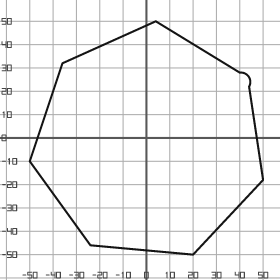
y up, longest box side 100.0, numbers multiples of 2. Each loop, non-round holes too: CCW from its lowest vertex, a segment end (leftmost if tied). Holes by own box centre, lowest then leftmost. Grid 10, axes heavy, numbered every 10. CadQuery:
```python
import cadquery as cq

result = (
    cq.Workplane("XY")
    .moveTo(20.0, -50.0)
    .lineTo(50.0, -18.0)
    .lineTo(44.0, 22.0)
    .threePointArc((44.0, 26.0), (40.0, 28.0))
    .lineTo(4.0, 50.0)
    .lineTo(-36.0, 32.0)
    .lineTo(-50.0, -10.0)
    .lineTo(-24.0, -46.0)
    .close()
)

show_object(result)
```